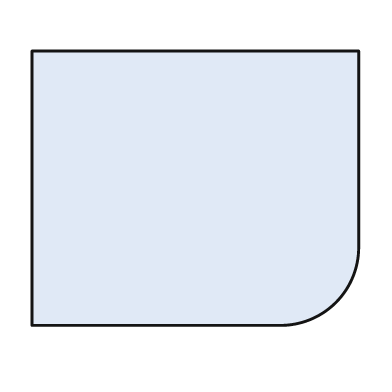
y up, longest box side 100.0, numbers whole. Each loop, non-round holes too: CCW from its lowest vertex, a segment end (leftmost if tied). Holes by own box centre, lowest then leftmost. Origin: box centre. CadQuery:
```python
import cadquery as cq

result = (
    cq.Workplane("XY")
    .moveTo(-50.0, -42.0)
    .lineTo(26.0, -42.0)
    .threePointArc((43.0, -35.0), (50.0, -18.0))
    .lineTo(50.0, 42.0)
    .lineTo(-50.0, 42.0)
    .close()
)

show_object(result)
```